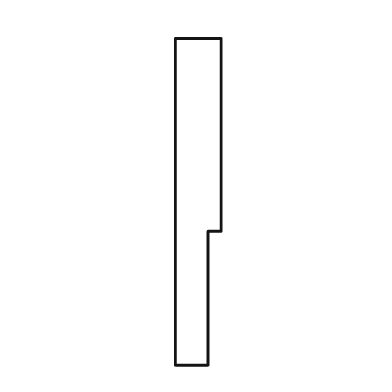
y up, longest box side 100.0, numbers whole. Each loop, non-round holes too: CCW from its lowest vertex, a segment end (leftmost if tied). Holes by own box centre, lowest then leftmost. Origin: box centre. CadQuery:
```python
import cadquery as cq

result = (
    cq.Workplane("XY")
    .moveTo(-7.0, -50.0)
    .lineTo(3.0, -50.0)
    .lineTo(3.0, -9.0)
    .lineTo(7.0, -9.0)
    .lineTo(7.0, 50.0)
    .lineTo(-7.0, 50.0)
    .close()
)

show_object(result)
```